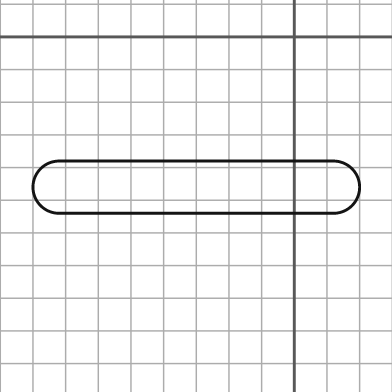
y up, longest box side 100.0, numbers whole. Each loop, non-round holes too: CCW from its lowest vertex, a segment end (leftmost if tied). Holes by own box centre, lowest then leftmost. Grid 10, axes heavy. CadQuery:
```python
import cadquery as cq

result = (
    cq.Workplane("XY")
    .moveTo(-72.0, -54.0)
    .lineTo(12.0, -54.0)
    .threePointArc((20.0, -46.0), (12.0, -38.0))
    .lineTo(-72.0, -38.0)
    .threePointArc((-80.0, -46.0), (-72.0, -54.0))
    .close()
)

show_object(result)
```